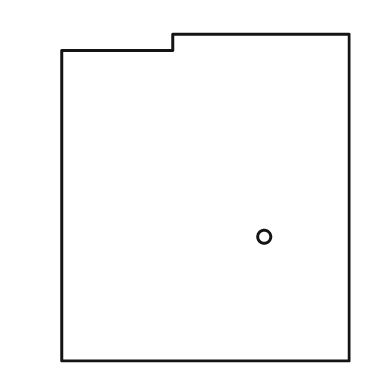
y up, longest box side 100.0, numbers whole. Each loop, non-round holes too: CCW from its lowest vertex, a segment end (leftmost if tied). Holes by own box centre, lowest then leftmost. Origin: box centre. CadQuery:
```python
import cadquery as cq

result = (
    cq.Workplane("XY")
    .moveTo(-44.0, -50.0)
    .lineTo(44.0, -50.0)
    .lineTo(44.0, 50.0)
    .lineTo(-10.0, 50.0)
    .lineTo(-10.0, 45.0)
    .lineTo(-44.0, 45.0)
    .close()
    .moveTo(18.0, -12.0)
    .circle(2.0)
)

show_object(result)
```